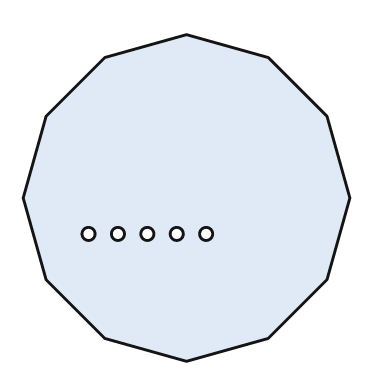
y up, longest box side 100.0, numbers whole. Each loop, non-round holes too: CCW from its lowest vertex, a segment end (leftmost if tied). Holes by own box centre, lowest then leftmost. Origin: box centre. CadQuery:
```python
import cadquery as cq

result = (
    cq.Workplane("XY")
    .moveTo(0.0, -50.0)
    .lineTo(25.0, -43.0)
    .lineTo(43.0, -25.0)
    .lineTo(50.0, 0.0)
    .lineTo(43.0, 25.0)
    .lineTo(25.0, 43.0)
    .lineTo(0.0, 50.0)
    .lineTo(-25.0, 43.0)
    .lineTo(-43.0, 25.0)
    .lineTo(-50.0, 0.0)
    .lineTo(-43.0, -25.0)
    .lineTo(-25.0, -43.0)
    .close()
    .moveTo(-30.0, -11.0)
    .circle(2.0)
    .moveTo(-21.0, -11.0)
    .circle(2.0)
    .moveTo(-12.0, -11.0)
    .circle(2.0)
    .moveTo(-3.0, -11.0)
    .circle(2.0)
    .moveTo(6.0, -11.0)
    .circle(2.0)
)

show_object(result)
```